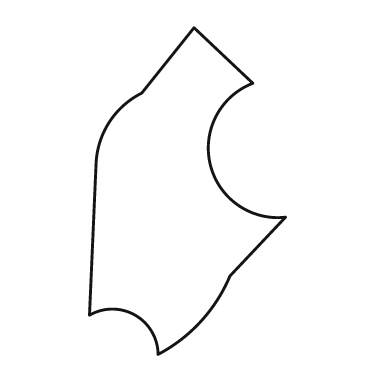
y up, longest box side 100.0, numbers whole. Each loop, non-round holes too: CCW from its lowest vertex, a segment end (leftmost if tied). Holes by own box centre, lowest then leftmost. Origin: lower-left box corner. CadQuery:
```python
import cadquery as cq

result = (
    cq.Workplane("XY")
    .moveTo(21.0, 0.0)
    .threePointArc((34.0, 10.0), (43.0, 24.0))
    .lineTo(60.0, 42.0)
    .threePointArc((37.0, 58.0), (50.0, 83.0))
    .lineTo(32.0, 100.0)
    .lineTo(16.0, 80.0)
    .threePointArc((6.0, 71.0), (2.0, 58.0))
    .lineTo(0.0, 12.0)
    .threePointArc((14.0, 12.0), (21.0, 0.0))
    .close()
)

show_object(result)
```